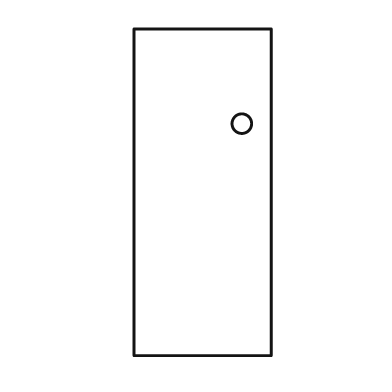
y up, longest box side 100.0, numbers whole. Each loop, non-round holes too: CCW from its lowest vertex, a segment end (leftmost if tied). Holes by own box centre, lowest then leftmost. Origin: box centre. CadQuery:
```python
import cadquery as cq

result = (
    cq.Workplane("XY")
    .moveTo(-21.0, -50.0)
    .lineTo(21.0, -50.0)
    .lineTo(21.0, 50.0)
    .lineTo(-21.0, 50.0)
    .close()
    .moveTo(12.0, 21.0)
    .circle(3.0)
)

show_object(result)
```